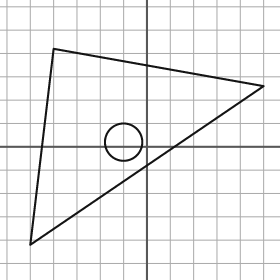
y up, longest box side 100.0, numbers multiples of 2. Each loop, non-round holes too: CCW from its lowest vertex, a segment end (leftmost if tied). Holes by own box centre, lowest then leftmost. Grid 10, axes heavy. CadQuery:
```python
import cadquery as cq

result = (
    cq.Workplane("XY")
    .moveTo(-50.0, -42.0)
    .lineTo(50.0, 26.0)
    .lineTo(-40.0, 42.0)
    .close()
    .moveTo(-10.0, 2.0)
    .circle(8.0)
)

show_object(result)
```